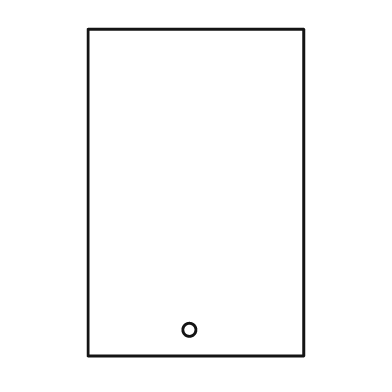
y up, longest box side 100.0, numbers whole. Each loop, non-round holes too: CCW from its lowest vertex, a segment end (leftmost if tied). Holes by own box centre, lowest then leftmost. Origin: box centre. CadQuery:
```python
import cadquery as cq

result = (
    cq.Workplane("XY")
    .moveTo(-33.0, -50.0)
    .lineTo(33.0, -50.0)
    .lineTo(33.0, 50.0)
    .lineTo(-33.0, 50.0)
    .close()
    .moveTo(-2.0, -42.0)
    .circle(2.0)
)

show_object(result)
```